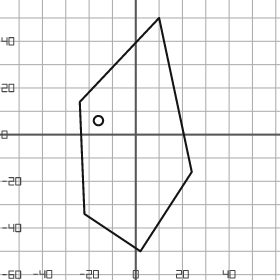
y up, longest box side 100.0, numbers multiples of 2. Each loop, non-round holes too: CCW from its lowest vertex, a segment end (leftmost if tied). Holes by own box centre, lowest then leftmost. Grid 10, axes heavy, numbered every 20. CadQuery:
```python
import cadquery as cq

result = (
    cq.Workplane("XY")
    .moveTo(2.0, -50.0)
    .lineTo(24.0, -16.0)
    .lineTo(10.0, 50.0)
    .lineTo(-24.0, 14.0)
    .lineTo(-22.0, -34.0)
    .close()
    .moveTo(-16.0, 6.0)
    .circle(2.0)
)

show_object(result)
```